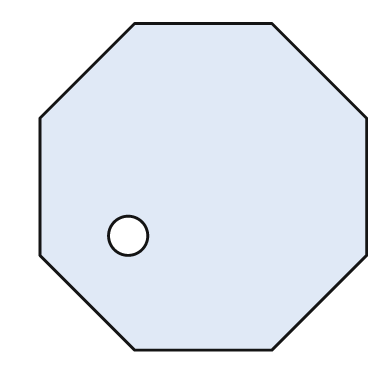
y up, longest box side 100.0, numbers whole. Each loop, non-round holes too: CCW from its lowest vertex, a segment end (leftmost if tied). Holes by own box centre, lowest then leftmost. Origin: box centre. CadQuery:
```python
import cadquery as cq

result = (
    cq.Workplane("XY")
    .moveTo(-21.0, -50.0)
    .lineTo(21.0, -50.0)
    .lineTo(50.0, -21.0)
    .lineTo(50.0, 21.0)
    .lineTo(21.0, 50.0)
    .lineTo(-21.0, 50.0)
    .lineTo(-50.0, 21.0)
    .lineTo(-50.0, -21.0)
    .close()
    .moveTo(-23.0, -15.0)
    .circle(6.0)
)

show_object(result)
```